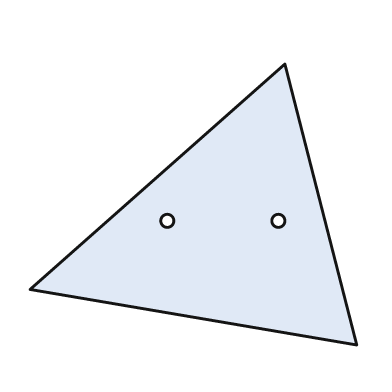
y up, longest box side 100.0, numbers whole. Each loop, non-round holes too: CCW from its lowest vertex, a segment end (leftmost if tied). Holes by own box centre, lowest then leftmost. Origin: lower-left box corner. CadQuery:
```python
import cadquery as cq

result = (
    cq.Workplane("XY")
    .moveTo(100.0, 0.0)
    .lineTo(78.0, 86.0)
    .lineTo(0.0, 17.0)
    .close()
    .moveTo(42.0, 38.0)
    .circle(2.0)
    .moveTo(76.0, 38.0)
    .circle(2.0)
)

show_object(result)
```